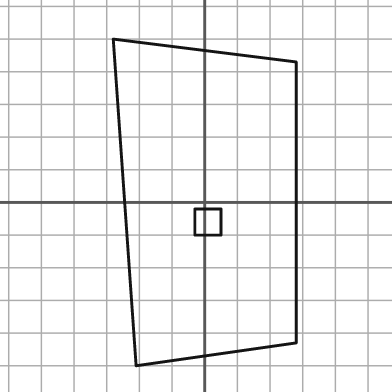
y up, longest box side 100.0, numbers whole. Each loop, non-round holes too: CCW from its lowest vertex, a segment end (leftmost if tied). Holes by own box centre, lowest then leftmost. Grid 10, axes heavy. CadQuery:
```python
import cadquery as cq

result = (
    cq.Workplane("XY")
    .moveTo(-21.0, -50.0)
    .lineTo(28.0, -43.0)
    .lineTo(28.0, 43.0)
    .lineTo(-28.0, 50.0)
    .close()
    .moveTo(-3.0, -10.0)
    .lineTo(5.0, -10.0)
    .lineTo(5.0, -2.0)
    .lineTo(-3.0, -2.0)
    .close()
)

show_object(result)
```